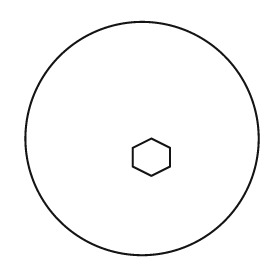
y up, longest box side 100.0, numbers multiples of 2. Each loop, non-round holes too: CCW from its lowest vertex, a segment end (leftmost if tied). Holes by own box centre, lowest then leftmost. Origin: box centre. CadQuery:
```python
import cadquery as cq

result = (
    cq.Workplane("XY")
    .moveTo(0.0, 0.0)
    .circle(50.0)
    .moveTo(4.0, -16.0)
    .lineTo(12.0, -12.0)
    .lineTo(12.0, -4.0)
    .lineTo(4.0, 0.0)
    .lineTo(-4.0, -4.0)
    .lineTo(-4.0, -12.0)
    .close()
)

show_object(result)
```